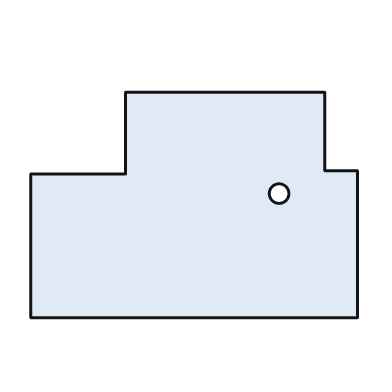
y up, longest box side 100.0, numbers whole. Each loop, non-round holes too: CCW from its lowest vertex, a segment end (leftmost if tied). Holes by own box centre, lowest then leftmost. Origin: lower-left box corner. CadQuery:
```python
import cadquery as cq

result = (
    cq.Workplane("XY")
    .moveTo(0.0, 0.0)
    .lineTo(100.0, 0.0)
    .lineTo(100.0, 45.0)
    .lineTo(90.0, 45.0)
    .lineTo(90.0, 69.0)
    .lineTo(29.0, 69.0)
    .lineTo(29.0, 44.0)
    .lineTo(0.0, 44.0)
    .close()
    .moveTo(76.0, 38.0)
    .circle(3.0)
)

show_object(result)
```